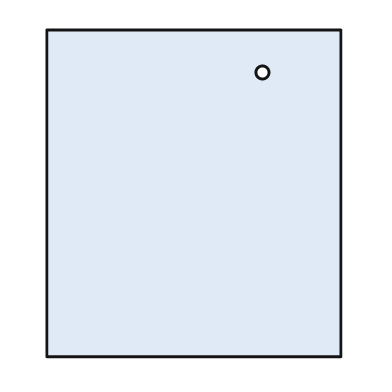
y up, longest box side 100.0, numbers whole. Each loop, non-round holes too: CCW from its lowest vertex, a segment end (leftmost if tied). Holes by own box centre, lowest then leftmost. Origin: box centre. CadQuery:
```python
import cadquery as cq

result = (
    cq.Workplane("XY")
    .moveTo(-45.0, -50.0)
    .lineTo(45.0, -50.0)
    .lineTo(45.0, 50.0)
    .lineTo(-45.0, 50.0)
    .close()
    .moveTo(21.0, 37.0)
    .circle(2.0)
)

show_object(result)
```